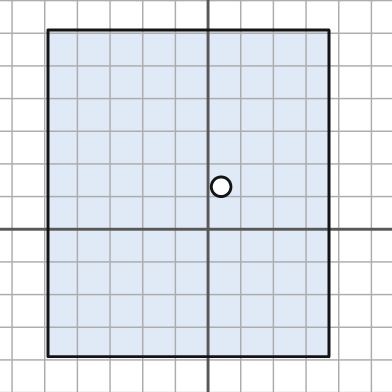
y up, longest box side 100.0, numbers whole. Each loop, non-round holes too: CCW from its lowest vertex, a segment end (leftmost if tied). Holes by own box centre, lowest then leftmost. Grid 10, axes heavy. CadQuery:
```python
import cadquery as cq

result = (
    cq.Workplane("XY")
    .moveTo(-49.0, -39.0)
    .lineTo(37.0, -39.0)
    .lineTo(37.0, 61.0)
    .lineTo(-49.0, 61.0)
    .close()
    .moveTo(4.0, 13.0)
    .circle(3.0)
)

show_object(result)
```